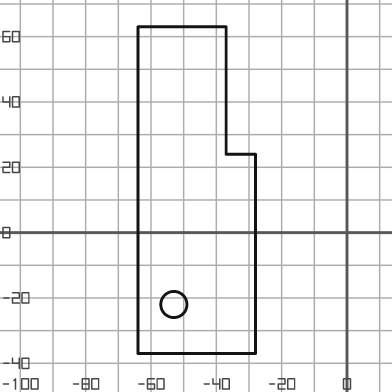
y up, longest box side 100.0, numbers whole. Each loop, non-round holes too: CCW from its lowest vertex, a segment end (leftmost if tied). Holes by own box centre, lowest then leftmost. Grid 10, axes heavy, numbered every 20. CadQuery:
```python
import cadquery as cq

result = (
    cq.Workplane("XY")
    .moveTo(-64.0, -37.0)
    .lineTo(-28.0, -37.0)
    .lineTo(-28.0, 24.0)
    .lineTo(-37.0, 24.0)
    .lineTo(-37.0, 63.0)
    .lineTo(-64.0, 63.0)
    .close()
    .moveTo(-53.0, -22.0)
    .circle(4.0)
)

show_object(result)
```